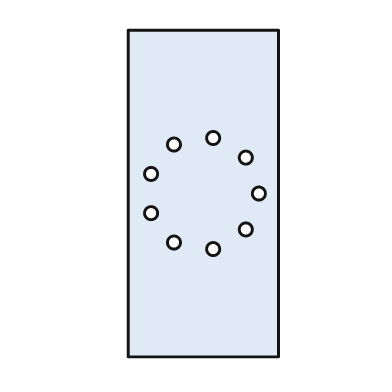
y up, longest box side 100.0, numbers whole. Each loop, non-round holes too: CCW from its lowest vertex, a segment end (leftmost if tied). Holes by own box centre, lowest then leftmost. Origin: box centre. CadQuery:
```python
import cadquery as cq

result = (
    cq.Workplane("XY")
    .moveTo(-23.0, -50.0)
    .lineTo(23.0, -50.0)
    .lineTo(23.0, 50.0)
    .lineTo(-23.0, 50.0)
    .close()
    .moveTo(3.0, -17.0)
    .circle(2.0)
    .moveTo(-9.0, -15.0)
    .circle(2.0)
    .moveTo(13.0, -11.0)
    .circle(2.0)
    .moveTo(-16.0, -6.0)
    .circle(2.0)
    .moveTo(17.0, 0.0)
    .circle(2.0)
    .moveTo(-16.0, 6.0)
    .circle(2.0)
    .moveTo(13.0, 11.0)
    .circle(2.0)
    .moveTo(-9.0, 15.0)
    .circle(2.0)
    .moveTo(3.0, 17.0)
    .circle(2.0)
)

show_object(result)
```